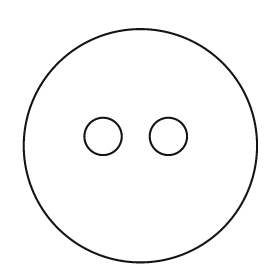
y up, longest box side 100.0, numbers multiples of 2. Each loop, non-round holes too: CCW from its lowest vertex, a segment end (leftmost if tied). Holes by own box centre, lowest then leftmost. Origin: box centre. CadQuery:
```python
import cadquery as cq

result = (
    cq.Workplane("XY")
    .moveTo(0.0, 0.0)
    .circle(50.0)
    .moveTo(-16.0, 4.0)
    .circle(8.0)
    .moveTo(12.0, 4.0)
    .circle(8.0)
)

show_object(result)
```